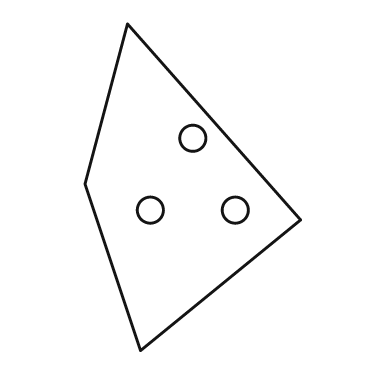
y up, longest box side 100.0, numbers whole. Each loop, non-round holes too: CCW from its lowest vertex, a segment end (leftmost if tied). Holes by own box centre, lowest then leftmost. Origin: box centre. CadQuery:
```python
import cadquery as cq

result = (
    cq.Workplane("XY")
    .moveTo(-16.0, -50.0)
    .lineTo(33.0, -10.0)
    .lineTo(-20.0, 50.0)
    .lineTo(-33.0, 1.0)
    .close()
    .moveTo(-13.0, -7.0)
    .circle(4.0)
    .moveTo(13.0, -7.0)
    .circle(4.0)
    .moveTo(0.0, 15.0)
    .circle(4.0)
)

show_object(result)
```